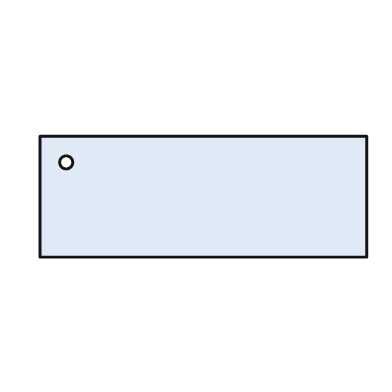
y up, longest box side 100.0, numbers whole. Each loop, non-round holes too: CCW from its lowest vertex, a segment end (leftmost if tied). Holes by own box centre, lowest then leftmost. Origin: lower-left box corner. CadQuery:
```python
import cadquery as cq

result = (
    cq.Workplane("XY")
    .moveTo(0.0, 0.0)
    .lineTo(100.0, 0.0)
    .lineTo(100.0, 37.0)
    .lineTo(0.0, 37.0)
    .close()
    .moveTo(8.0, 29.0)
    .circle(2.0)
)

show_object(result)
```